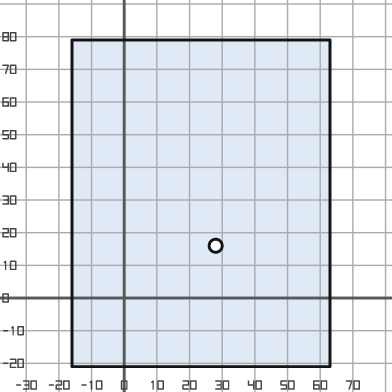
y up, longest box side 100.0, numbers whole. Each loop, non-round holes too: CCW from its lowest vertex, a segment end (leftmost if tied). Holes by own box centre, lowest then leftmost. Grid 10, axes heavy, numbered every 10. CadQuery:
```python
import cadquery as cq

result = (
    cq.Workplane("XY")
    .moveTo(-16.0, -21.0)
    .lineTo(63.0, -21.0)
    .lineTo(63.0, 79.0)
    .lineTo(-16.0, 79.0)
    .close()
    .moveTo(28.0, 16.0)
    .circle(2.0)
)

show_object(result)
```